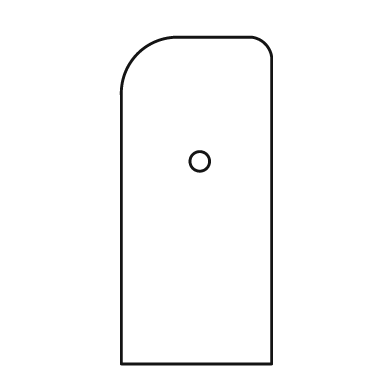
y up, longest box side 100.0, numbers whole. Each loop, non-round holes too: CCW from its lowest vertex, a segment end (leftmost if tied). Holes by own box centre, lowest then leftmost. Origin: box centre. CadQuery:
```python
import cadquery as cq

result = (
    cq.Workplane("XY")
    .moveTo(-23.0, -50.0)
    .lineTo(23.0, -50.0)
    .lineTo(23.0, 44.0)
    .threePointArc((21.0, 48.0), (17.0, 50.0))
    .lineTo(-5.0, 50.0)
    .threePointArc((-18.0, 45.0), (-23.0, 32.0))
    .close()
    .moveTo(1.0, 12.0)
    .circle(3.0)
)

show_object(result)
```